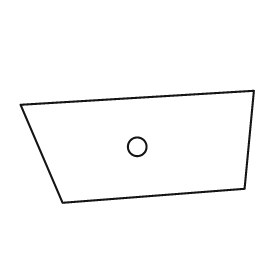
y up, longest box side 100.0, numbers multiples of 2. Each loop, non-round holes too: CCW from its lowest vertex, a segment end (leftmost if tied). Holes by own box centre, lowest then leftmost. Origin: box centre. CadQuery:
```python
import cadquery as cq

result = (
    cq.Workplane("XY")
    .moveTo(-32.0, -24.0)
    .lineTo(46.0, -18.0)
    .lineTo(50.0, 24.0)
    .lineTo(-50.0, 18.0)
    .close()
    .moveTo(0.0, 0.0)
    .circle(4.0)
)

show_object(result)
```